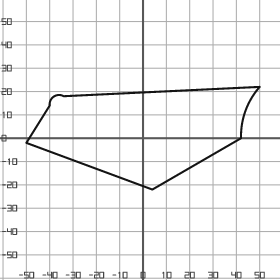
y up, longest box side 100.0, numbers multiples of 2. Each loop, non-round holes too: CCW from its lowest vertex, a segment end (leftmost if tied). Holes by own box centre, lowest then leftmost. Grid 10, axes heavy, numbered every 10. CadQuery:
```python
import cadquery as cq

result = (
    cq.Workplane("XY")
    .moveTo(4.0, -22.0)
    .lineTo(42.0, 0.0)
    .threePointArc((44.0, 12.0), (50.0, 22.0))
    .lineTo(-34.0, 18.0)
    .threePointArc((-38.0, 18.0), (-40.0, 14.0))
    .lineTo(-50.0, -2.0)
    .close()
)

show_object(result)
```